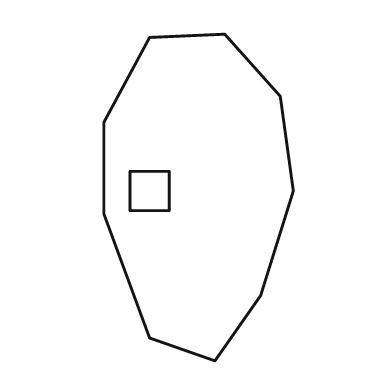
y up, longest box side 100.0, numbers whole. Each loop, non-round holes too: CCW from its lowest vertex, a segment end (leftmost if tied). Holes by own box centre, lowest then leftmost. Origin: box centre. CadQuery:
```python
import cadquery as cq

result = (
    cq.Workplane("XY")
    .moveTo(5.0, -50.0)
    .lineTo(19.0, -30.0)
    .lineTo(29.0, 2.0)
    .lineTo(25.0, 31.0)
    .lineTo(8.0, 50.0)
    .lineTo(-15.0, 49.0)
    .lineTo(-29.0, 23.0)
    .lineTo(-29.0, -5.0)
    .lineTo(-15.0, -43.0)
    .close()
    .moveTo(-21.0, -4.0)
    .lineTo(-9.0, -4.0)
    .lineTo(-9.0, 8.0)
    .lineTo(-21.0, 8.0)
    .close()
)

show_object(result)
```